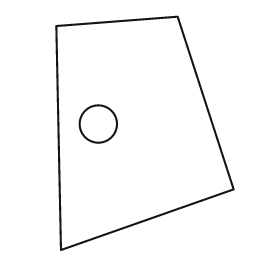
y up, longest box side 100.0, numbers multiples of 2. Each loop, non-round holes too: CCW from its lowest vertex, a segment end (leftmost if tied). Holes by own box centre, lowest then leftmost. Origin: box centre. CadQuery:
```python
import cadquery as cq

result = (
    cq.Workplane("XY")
    .moveTo(-36.0, -50.0)
    .lineTo(38.0, -24.0)
    .lineTo(14.0, 50.0)
    .lineTo(-38.0, 46.0)
    .close()
    .moveTo(-20.0, 4.0)
    .circle(8.0)
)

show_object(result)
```